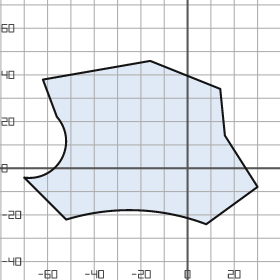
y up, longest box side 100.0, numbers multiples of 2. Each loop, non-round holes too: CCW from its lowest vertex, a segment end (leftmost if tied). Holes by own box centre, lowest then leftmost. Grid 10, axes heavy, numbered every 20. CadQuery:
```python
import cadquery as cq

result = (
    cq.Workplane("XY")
    .moveTo(8.0, -24.0)
    .lineTo(30.0, -8.0)
    .lineTo(16.0, 14.0)
    .lineTo(14.0, 34.0)
    .lineTo(-16.0, 46.0)
    .lineTo(-62.0, 38.0)
    .lineTo(-56.0, 22.0)
    .threePointArc((-54.0, 4.0), (-70.0, -4.0))
    .lineTo(-52.0, -22.0)
    .threePointArc((-22.0, -18.0), (8.0, -24.0))
    .close()
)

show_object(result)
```